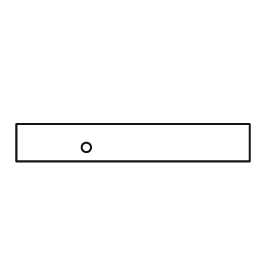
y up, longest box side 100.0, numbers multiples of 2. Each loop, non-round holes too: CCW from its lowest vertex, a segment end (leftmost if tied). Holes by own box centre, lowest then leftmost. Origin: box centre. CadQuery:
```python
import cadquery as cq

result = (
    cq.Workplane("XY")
    .moveTo(-50.0, -8.0)
    .lineTo(50.0, -8.0)
    .lineTo(50.0, 8.0)
    .lineTo(-50.0, 8.0)
    .close()
    .moveTo(-20.0, -2.0)
    .circle(2.0)
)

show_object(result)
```